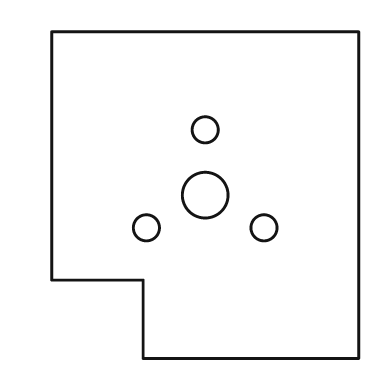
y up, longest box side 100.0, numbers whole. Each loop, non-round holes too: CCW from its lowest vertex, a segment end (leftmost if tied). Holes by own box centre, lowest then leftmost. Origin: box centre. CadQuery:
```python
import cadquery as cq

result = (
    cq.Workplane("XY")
    .moveTo(-19.0, -50.0)
    .lineTo(47.0, -50.0)
    .lineTo(47.0, 50.0)
    .lineTo(-47.0, 50.0)
    .lineTo(-47.0, -26.0)
    .lineTo(-19.0, -26.0)
    .close()
    .moveTo(-18.0, -10.0)
    .circle(4.0)
    .moveTo(18.0, -10.0)
    .circle(4.0)
    .moveTo(0.0, 0.0)
    .circle(7.0)
    .moveTo(0.0, 20.0)
    .circle(4.0)
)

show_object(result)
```